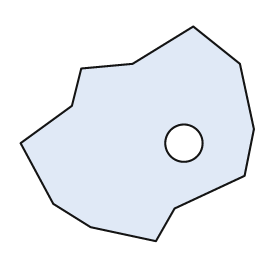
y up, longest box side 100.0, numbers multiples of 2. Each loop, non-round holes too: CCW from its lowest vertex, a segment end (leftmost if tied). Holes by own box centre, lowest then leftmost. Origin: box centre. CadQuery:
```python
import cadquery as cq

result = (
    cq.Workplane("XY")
    .moveTo(8.0, -46.0)
    .lineTo(16.0, -32.0)
    .lineTo(46.0, -18.0)
    .lineTo(50.0, 2.0)
    .lineTo(44.0, 30.0)
    .lineTo(24.0, 46.0)
    .lineTo(-2.0, 30.0)
    .lineTo(-24.0, 28.0)
    .lineTo(-28.0, 12.0)
    .lineTo(-50.0, -4.0)
    .lineTo(-36.0, -30.0)
    .lineTo(-20.0, -40.0)
    .close()
    .moveTo(20.0, -4.0)
    .circle(8.0)
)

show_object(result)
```